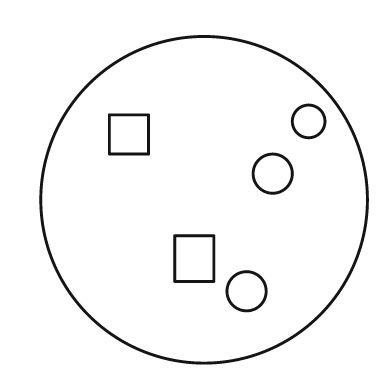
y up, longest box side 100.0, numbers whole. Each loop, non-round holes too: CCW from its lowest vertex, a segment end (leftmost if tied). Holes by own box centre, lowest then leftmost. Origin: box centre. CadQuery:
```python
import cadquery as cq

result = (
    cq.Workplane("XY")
    .moveTo(0.0, 0.0)
    .circle(50.0)
    .moveTo(13.0, -28.0)
    .circle(6.0)
    .moveTo(-9.0, -25.0)
    .lineTo(3.0, -25.0)
    .lineTo(3.0, -11.0)
    .lineTo(-9.0, -11.0)
    .close()
    .moveTo(21.0, 8.0)
    .circle(6.0)
    .moveTo(-29.0, 14.0)
    .lineTo(-17.0, 14.0)
    .lineTo(-17.0, 26.0)
    .lineTo(-29.0, 26.0)
    .close()
    .moveTo(32.0, 24.0)
    .circle(5.0)
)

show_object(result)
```